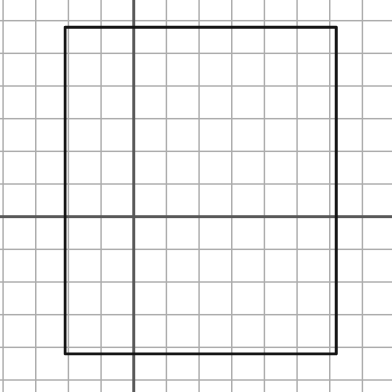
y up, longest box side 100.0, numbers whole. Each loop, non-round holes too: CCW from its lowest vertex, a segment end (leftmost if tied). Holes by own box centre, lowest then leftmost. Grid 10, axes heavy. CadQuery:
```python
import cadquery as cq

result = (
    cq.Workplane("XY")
    .moveTo(-21.0, -42.0)
    .lineTo(62.0, -42.0)
    .lineTo(62.0, 58.0)
    .lineTo(-21.0, 58.0)
    .close()
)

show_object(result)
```